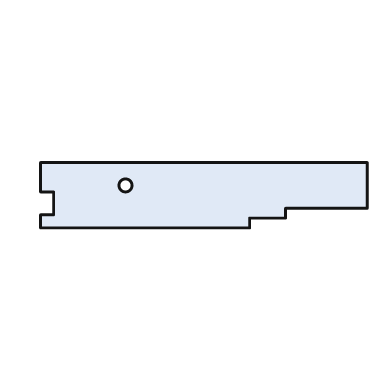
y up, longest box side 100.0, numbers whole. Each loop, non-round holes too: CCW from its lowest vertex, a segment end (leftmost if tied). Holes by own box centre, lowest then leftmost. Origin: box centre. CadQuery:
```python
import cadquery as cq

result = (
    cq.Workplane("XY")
    .moveTo(-50.0, -10.0)
    .lineTo(14.0, -10.0)
    .lineTo(14.0, -7.0)
    .lineTo(25.0, -7.0)
    .lineTo(25.0, -4.0)
    .lineTo(50.0, -4.0)
    .lineTo(50.0, 10.0)
    .lineTo(-50.0, 10.0)
    .lineTo(-50.0, 1.0)
    .lineTo(-46.0, 1.0)
    .lineTo(-46.0, -6.0)
    .lineTo(-50.0, -6.0)
    .close()
    .moveTo(-24.0, 3.0)
    .circle(2.0)
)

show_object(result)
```